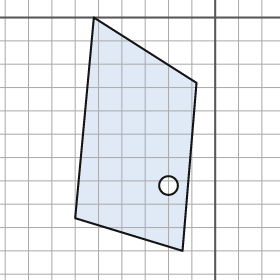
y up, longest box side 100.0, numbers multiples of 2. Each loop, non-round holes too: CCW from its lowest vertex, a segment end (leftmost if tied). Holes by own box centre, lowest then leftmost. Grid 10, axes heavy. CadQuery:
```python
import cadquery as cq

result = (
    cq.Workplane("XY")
    .moveTo(-14.0, -100.0)
    .lineTo(-8.0, -28.0)
    .lineTo(-52.0, 0.0)
    .lineTo(-60.0, -86.0)
    .close()
    .moveTo(-20.0, -72.0)
    .circle(4.0)
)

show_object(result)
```